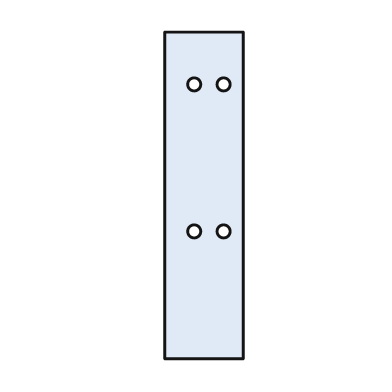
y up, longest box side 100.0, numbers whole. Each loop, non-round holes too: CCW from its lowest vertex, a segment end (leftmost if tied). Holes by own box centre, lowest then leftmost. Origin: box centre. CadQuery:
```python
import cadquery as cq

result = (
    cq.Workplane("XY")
    .moveTo(-12.0, -50.0)
    .lineTo(12.0, -50.0)
    .lineTo(12.0, 50.0)
    .lineTo(-12.0, 50.0)
    .close()
    .moveTo(-3.0, -11.0)
    .circle(2.0)
    .moveTo(6.0, -11.0)
    .circle(2.0)
    .moveTo(-3.0, 34.0)
    .circle(2.0)
    .moveTo(6.0, 34.0)
    .circle(2.0)
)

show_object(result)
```